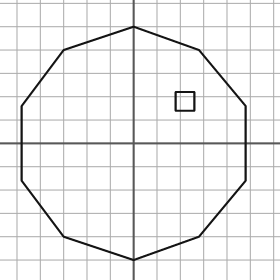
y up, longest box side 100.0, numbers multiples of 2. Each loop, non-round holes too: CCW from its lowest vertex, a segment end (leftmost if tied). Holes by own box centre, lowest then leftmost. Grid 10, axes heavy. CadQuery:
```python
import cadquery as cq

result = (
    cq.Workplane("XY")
    .moveTo(0.0, -50.0)
    .lineTo(28.0, -40.0)
    .lineTo(48.0, -16.0)
    .lineTo(48.0, 16.0)
    .lineTo(28.0, 40.0)
    .lineTo(0.0, 50.0)
    .lineTo(-30.0, 40.0)
    .lineTo(-48.0, 16.0)
    .lineTo(-48.0, -16.0)
    .lineTo(-30.0, -40.0)
    .close()
    .moveTo(18.0, 14.0)
    .lineTo(26.0, 14.0)
    .lineTo(26.0, 22.0)
    .lineTo(18.0, 22.0)
    .close()
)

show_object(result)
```